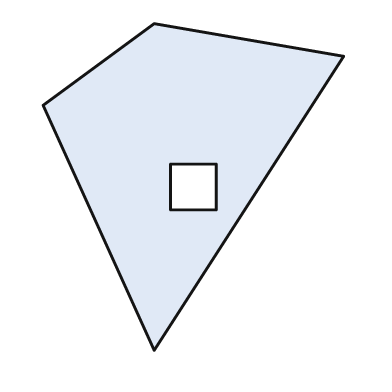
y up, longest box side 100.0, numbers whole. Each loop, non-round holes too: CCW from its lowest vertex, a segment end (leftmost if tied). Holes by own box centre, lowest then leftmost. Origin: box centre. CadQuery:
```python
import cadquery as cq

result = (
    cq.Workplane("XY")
    .moveTo(-12.0, -50.0)
    .lineTo(46.0, 40.0)
    .lineTo(-12.0, 50.0)
    .lineTo(-46.0, 25.0)
    .close()
    .moveTo(-7.0, -7.0)
    .lineTo(7.0, -7.0)
    .lineTo(7.0, 7.0)
    .lineTo(-7.0, 7.0)
    .close()
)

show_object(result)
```